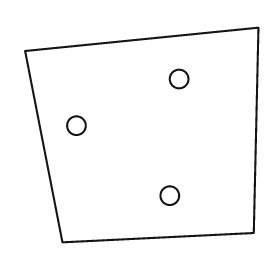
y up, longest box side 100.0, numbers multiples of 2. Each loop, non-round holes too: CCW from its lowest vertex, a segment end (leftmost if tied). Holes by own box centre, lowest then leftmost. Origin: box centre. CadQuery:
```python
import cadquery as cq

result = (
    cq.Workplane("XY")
    .moveTo(-34.0, -46.0)
    .lineTo(48.0, -42.0)
    .lineTo(50.0, 46.0)
    .lineTo(-50.0, 36.0)
    .close()
    .moveTo(12.0, -26.0)
    .circle(4.0)
    .moveTo(-28.0, 4.0)
    .circle(4.0)
    .moveTo(16.0, 24.0)
    .circle(4.0)
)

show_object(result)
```